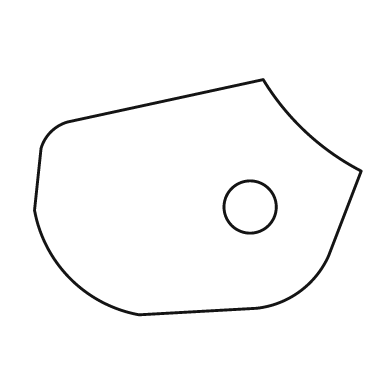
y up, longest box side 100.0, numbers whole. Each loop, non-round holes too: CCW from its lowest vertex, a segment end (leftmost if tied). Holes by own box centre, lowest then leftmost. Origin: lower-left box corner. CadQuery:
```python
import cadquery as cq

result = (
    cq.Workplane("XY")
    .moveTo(32.0, 0.0)
    .lineTo(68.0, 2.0)
    .threePointArc((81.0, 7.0), (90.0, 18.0))
    .lineTo(100.0, 44.0)
    .threePointArc((83.0, 56.0), (70.0, 72.0))
    .lineTo(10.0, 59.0)
    .threePointArc((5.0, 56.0), (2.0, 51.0))
    .lineTo(0.0, 32.0)
    .threePointArc((11.0, 11.0), (32.0, 0.0))
    .close()
    .moveTo(66.0, 33.0)
    .circle(8.0)
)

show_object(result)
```